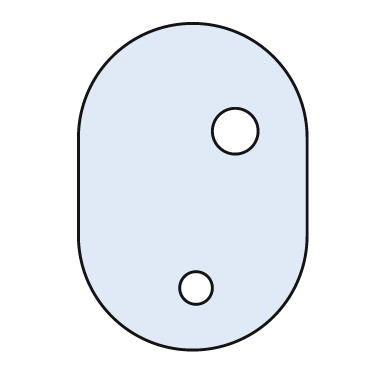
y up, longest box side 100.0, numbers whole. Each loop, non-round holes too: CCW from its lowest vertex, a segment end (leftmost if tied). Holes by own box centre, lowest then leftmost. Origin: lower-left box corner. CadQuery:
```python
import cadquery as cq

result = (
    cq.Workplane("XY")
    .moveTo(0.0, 35.0)
    .threePointArc((35.0, 0.0), (70.0, 35.0))
    .lineTo(70.0, 65.0)
    .threePointArc((35.0, 100.0), (0.0, 65.0))
    .close()
    .moveTo(36.0, 19.0)
    .circle(5.0)
    .moveTo(48.0, 67.0)
    .circle(7.0)
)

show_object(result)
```